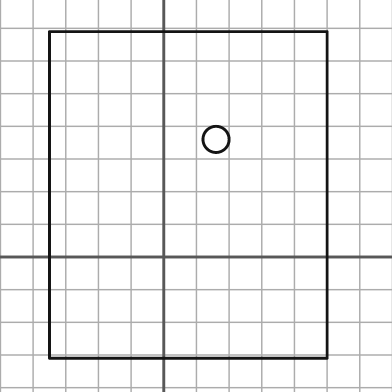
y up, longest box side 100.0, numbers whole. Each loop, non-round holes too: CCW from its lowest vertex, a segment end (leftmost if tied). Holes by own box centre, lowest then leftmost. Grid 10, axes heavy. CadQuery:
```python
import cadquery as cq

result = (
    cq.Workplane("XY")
    .moveTo(-35.0, -31.0)
    .lineTo(50.0, -31.0)
    .lineTo(50.0, 69.0)
    .lineTo(-35.0, 69.0)
    .close()
    .moveTo(16.0, 36.0)
    .circle(4.0)
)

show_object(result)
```